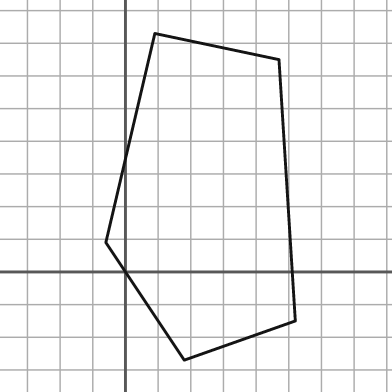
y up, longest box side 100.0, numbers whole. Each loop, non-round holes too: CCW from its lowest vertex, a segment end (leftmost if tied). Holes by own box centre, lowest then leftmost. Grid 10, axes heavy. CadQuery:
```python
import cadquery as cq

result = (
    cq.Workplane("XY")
    .moveTo(18.0, -27.0)
    .lineTo(52.0, -15.0)
    .lineTo(47.0, 65.0)
    .lineTo(9.0, 73.0)
    .lineTo(-6.0, 9.0)
    .close()
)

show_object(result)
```